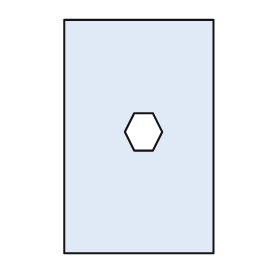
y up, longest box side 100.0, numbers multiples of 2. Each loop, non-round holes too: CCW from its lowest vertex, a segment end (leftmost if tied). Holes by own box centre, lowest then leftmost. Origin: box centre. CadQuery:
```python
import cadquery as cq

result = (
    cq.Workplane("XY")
    .moveTo(-32.0, -50.0)
    .lineTo(32.0, -50.0)
    .lineTo(32.0, 50.0)
    .lineTo(-32.0, 50.0)
    .close()
    .moveTo(-2.0, -6.0)
    .lineTo(6.0, -6.0)
    .lineTo(10.0, 2.0)
    .lineTo(6.0, 10.0)
    .lineTo(-2.0, 10.0)
    .lineTo(-6.0, 2.0)
    .close()
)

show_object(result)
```